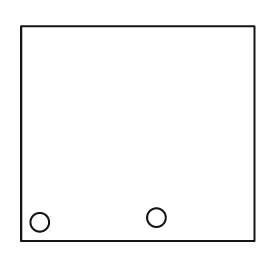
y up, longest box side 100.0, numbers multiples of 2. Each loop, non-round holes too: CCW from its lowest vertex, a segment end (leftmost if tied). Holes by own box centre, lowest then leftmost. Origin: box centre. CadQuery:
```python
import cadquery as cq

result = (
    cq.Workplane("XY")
    .moveTo(-50.0, -46.0)
    .lineTo(50.0, -46.0)
    .lineTo(50.0, 46.0)
    .lineTo(-50.0, 46.0)
    .close()
    .moveTo(-42.0, -38.0)
    .circle(4.0)
    .moveTo(8.0, -36.0)
    .circle(4.0)
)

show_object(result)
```